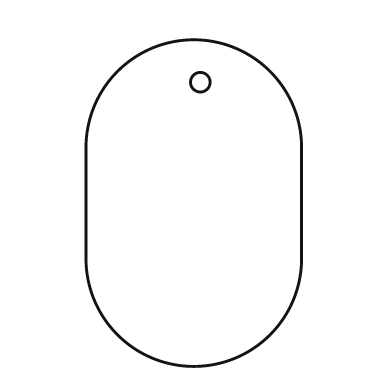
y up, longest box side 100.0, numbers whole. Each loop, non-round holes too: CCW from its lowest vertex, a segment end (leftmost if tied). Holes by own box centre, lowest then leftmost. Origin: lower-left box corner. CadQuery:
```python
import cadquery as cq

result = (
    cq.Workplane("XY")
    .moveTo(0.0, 33.0)
    .threePointArc((33.0, 0.0), (66.0, 33.0))
    .lineTo(66.0, 67.0)
    .threePointArc((33.0, 100.0), (0.0, 67.0))
    .close()
    .moveTo(35.0, 87.0)
    .circle(3.0)
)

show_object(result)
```